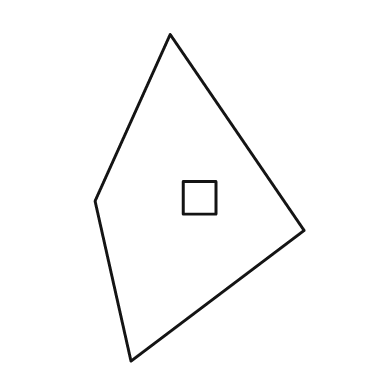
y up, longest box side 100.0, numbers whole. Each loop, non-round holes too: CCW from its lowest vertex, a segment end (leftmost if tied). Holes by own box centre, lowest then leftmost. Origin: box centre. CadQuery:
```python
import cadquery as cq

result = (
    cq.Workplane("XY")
    .moveTo(-21.0, -50.0)
    .lineTo(32.0, -10.0)
    .lineTo(-9.0, 50.0)
    .lineTo(-32.0, -1.0)
    .close()
    .moveTo(-5.0, -5.0)
    .lineTo(5.0, -5.0)
    .lineTo(5.0, 5.0)
    .lineTo(-5.0, 5.0)
    .close()
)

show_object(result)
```